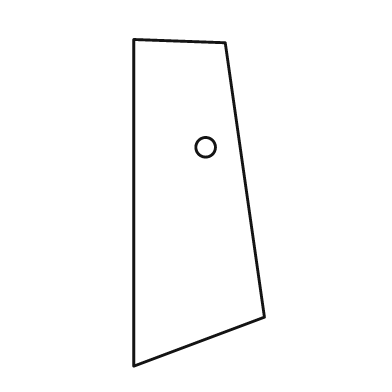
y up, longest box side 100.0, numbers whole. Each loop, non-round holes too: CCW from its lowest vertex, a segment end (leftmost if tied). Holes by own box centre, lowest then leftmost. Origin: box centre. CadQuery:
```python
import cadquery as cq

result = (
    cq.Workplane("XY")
    .moveTo(-20.0, -50.0)
    .lineTo(20.0, -35.0)
    .lineTo(8.0, 49.0)
    .lineTo(-20.0, 50.0)
    .close()
    .moveTo(2.0, 17.0)
    .circle(3.0)
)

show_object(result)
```